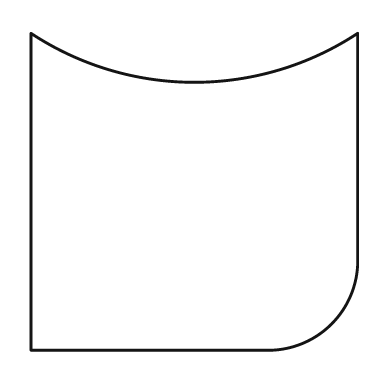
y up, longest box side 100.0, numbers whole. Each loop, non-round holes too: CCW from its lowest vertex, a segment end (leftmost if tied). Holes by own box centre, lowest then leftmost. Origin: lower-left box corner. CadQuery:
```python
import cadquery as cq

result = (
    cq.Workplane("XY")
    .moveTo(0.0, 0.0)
    .lineTo(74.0, 0.0)
    .threePointArc((92.0, 8.0), (100.0, 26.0))
    .lineTo(100.0, 97.0)
    .threePointArc((50.0, 82.0), (0.0, 97.0))
    .close()
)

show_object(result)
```